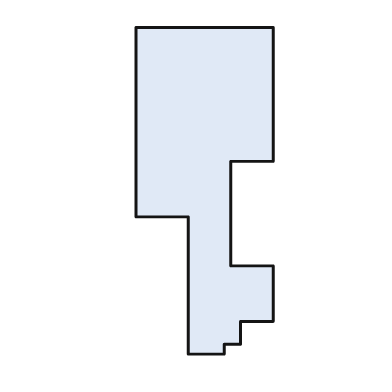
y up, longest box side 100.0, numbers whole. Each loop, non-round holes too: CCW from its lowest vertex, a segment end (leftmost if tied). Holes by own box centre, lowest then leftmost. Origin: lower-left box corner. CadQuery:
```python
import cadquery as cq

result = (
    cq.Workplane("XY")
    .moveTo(16.0, 0.0)
    .lineTo(27.0, 0.0)
    .lineTo(27.0, 3.0)
    .lineTo(32.0, 3.0)
    .lineTo(32.0, 10.0)
    .lineTo(42.0, 10.0)
    .lineTo(42.0, 27.0)
    .lineTo(29.0, 27.0)
    .lineTo(29.0, 59.0)
    .lineTo(42.0, 59.0)
    .lineTo(42.0, 100.0)
    .lineTo(0.0, 100.0)
    .lineTo(0.0, 42.0)
    .lineTo(16.0, 42.0)
    .close()
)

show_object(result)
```